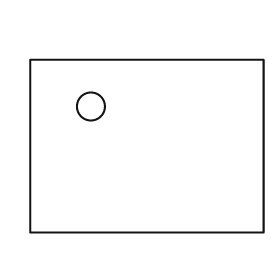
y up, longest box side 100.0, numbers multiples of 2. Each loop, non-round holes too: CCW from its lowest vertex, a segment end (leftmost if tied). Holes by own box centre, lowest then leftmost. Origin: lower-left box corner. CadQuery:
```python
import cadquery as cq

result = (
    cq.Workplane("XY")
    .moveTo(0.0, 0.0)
    .lineTo(100.0, 0.0)
    .lineTo(100.0, 74.0)
    .lineTo(0.0, 74.0)
    .close()
    .moveTo(26.0, 54.0)
    .circle(6.0)
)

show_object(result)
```